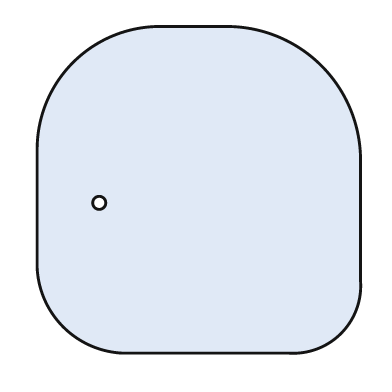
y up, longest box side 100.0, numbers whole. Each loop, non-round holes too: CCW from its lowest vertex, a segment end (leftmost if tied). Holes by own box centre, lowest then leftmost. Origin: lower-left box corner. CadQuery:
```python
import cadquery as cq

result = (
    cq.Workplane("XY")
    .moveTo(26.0, 0.0)
    .lineTo(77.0, 0.0)
    .threePointArc((93.0, 6.0), (99.0, 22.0))
    .lineTo(99.0, 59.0)
    .threePointArc((87.0, 88.0), (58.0, 100.0))
    .lineTo(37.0, 100.0)
    .threePointArc((11.0, 89.0), (0.0, 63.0))
    .lineTo(0.0, 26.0)
    .threePointArc((8.0, 8.0), (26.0, 0.0))
    .close()
    .moveTo(19.0, 46.0)
    .circle(2.0)
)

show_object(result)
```